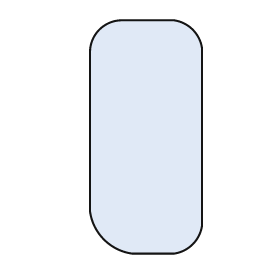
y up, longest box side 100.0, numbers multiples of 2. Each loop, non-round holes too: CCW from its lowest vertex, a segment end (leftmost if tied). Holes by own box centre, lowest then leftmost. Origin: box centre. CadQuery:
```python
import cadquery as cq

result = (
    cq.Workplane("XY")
    .moveTo(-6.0, -50.0)
    .lineTo(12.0, -50.0)
    .threePointArc((20.0, -46.0), (24.0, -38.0))
    .lineTo(24.0, 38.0)
    .threePointArc((20.0, 46.0), (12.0, 50.0))
    .lineTo(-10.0, 50.0)
    .threePointArc((-20.0, 46.0), (-24.0, 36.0))
    .lineTo(-24.0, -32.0)
    .threePointArc((-18.0, -44.0), (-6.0, -50.0))
    .close()
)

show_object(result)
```